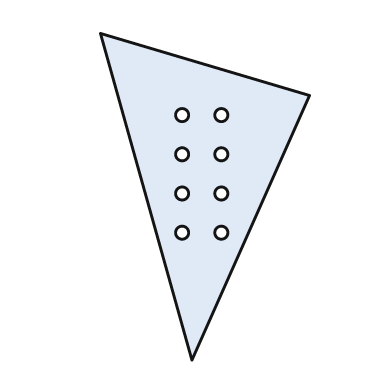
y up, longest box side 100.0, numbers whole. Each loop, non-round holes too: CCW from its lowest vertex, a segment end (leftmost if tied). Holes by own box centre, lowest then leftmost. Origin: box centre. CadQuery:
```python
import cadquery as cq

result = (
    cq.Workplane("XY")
    .moveTo(-4.0, -50.0)
    .lineTo(32.0, 31.0)
    .lineTo(-32.0, 50.0)
    .close()
    .moveTo(-7.0, -11.0)
    .circle(2.0)
    .moveTo(5.0, -11.0)
    .circle(2.0)
    .moveTo(-7.0, 1.0)
    .circle(2.0)
    .moveTo(5.0, 1.0)
    .circle(2.0)
    .moveTo(-7.0, 13.0)
    .circle(2.0)
    .moveTo(5.0, 13.0)
    .circle(2.0)
    .moveTo(-7.0, 25.0)
    .circle(2.0)
    .moveTo(5.0, 25.0)
    .circle(2.0)
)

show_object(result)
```